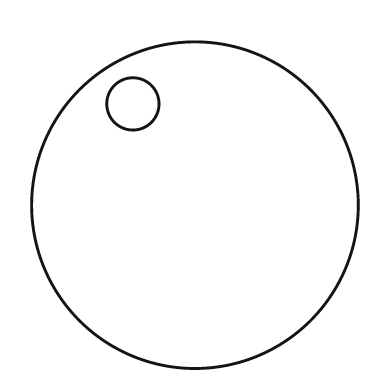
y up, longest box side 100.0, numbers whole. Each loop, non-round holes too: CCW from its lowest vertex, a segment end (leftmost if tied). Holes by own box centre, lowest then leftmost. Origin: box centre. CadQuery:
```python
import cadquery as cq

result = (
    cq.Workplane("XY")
    .moveTo(0.0, 0.0)
    .circle(50.0)
    .moveTo(-19.0, 31.0)
    .circle(8.0)
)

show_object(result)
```